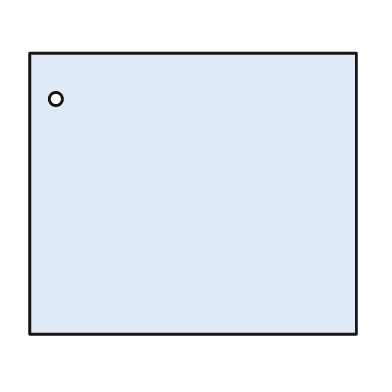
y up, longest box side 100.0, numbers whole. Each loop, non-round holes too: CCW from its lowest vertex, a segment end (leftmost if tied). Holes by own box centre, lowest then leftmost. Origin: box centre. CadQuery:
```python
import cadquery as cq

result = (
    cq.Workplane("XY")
    .moveTo(-50.0, -43.0)
    .lineTo(50.0, -43.0)
    .lineTo(50.0, 43.0)
    .lineTo(-50.0, 43.0)
    .close()
    .moveTo(-42.0, 29.0)
    .circle(2.0)
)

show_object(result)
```